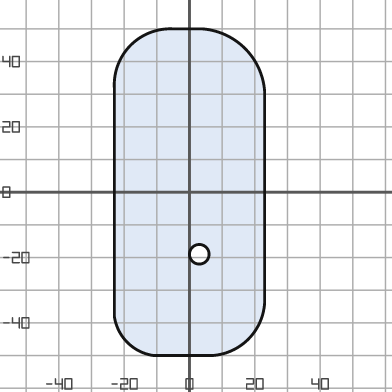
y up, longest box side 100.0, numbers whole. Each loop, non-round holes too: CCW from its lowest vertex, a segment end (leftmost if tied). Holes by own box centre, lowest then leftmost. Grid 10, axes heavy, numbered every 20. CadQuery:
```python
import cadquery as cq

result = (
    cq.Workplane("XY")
    .moveTo(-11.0, -50.0)
    .lineTo(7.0, -50.0)
    .threePointArc((18.0, -45.0), (23.0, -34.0))
    .lineTo(23.0, 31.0)
    .threePointArc((17.0, 44.0), (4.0, 50.0))
    .lineTo(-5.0, 50.0)
    .threePointArc((-18.0, 45.0), (-23.0, 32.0))
    .lineTo(-23.0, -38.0)
    .threePointArc((-19.0, -46.0), (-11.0, -50.0))
    .close()
    .moveTo(3.0, -19.0)
    .circle(3.0)
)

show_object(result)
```